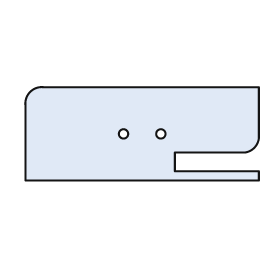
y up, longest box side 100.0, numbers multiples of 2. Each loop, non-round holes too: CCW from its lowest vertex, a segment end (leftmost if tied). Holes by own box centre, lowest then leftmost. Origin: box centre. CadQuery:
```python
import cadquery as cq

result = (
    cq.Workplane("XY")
    .moveTo(-50.0, -20.0)
    .lineTo(50.0, -20.0)
    .lineTo(50.0, -16.0)
    .lineTo(14.0, -16.0)
    .lineTo(14.0, -8.0)
    .lineTo(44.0, -8.0)
    .threePointArc((48.0, -6.0), (50.0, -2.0))
    .lineTo(50.0, 20.0)
    .lineTo(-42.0, 20.0)
    .threePointArc((-48.0, 18.0), (-50.0, 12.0))
    .close()
    .moveTo(-8.0, 0.0)
    .circle(2.0)
    .moveTo(8.0, 0.0)
    .circle(2.0)
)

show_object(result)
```